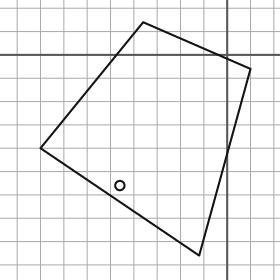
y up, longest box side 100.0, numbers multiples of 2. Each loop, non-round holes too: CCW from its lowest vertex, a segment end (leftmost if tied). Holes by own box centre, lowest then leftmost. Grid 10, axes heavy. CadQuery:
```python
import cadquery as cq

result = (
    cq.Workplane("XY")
    .moveTo(-12.0, -86.0)
    .lineTo(10.0, -6.0)
    .lineTo(-36.0, 14.0)
    .lineTo(-80.0, -40.0)
    .close()
    .moveTo(-46.0, -56.0)
    .circle(2.0)
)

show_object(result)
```